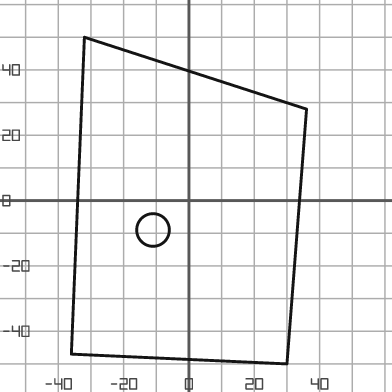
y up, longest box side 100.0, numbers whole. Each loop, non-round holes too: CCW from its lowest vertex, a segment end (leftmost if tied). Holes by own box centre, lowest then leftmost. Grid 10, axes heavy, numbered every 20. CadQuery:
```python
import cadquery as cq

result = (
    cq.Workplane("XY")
    .moveTo(30.0, -50.0)
    .lineTo(36.0, 28.0)
    .lineTo(-32.0, 50.0)
    .lineTo(-36.0, -47.0)
    .close()
    .moveTo(-11.0, -9.0)
    .circle(5.0)
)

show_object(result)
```